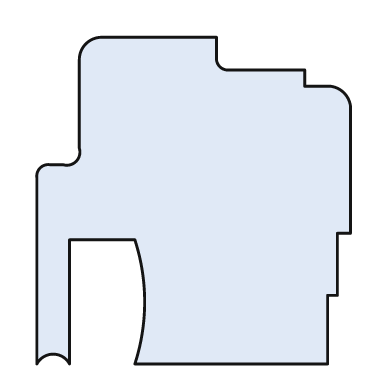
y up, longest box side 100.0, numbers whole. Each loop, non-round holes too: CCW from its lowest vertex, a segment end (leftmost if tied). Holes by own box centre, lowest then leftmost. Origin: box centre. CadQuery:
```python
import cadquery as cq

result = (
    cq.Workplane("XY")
    .moveTo(-48.0, -50.0)
    .threePointArc((-43.0, -47.0), (-38.0, -50.0))
    .lineTo(-38.0, -12.0)
    .lineTo(-18.0, -12.0)
    .threePointArc((-15.0, -31.0), (-18.0, -50.0))
    .lineTo(41.0, -50.0)
    .lineTo(41.0, -29.0)
    .lineTo(44.0, -29.0)
    .lineTo(44.0, -10.0)
    .lineTo(48.0, -10.0)
    .lineTo(48.0, 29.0)
    .threePointArc((46.0, 33.0), (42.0, 35.0))
    .lineTo(34.0, 35.0)
    .lineTo(34.0, 40.0)
    .lineTo(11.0, 40.0)
    .threePointArc((8.0, 41.0), (7.0, 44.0))
    .lineTo(7.0, 50.0)
    .lineTo(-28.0, 50.0)
    .threePointArc((-33.0, 48.0), (-35.0, 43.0))
    .lineTo(-35.0, 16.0)
    .threePointArc((-36.0, 12.0), (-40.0, 11.0))
    .lineTo(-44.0, 11.0)
    .threePointArc((-47.0, 10.0), (-48.0, 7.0))
    .close()
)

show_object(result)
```